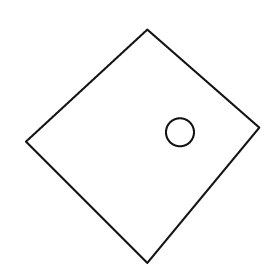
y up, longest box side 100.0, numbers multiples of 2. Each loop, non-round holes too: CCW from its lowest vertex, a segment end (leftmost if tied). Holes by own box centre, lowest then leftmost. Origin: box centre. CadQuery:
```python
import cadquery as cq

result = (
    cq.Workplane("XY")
    .moveTo(2.0, -50.0)
    .lineTo(50.0, 8.0)
    .lineTo(2.0, 50.0)
    .lineTo(-50.0, 2.0)
    .close()
    .moveTo(16.0, 6.0)
    .circle(6.0)
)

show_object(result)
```